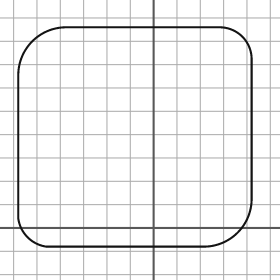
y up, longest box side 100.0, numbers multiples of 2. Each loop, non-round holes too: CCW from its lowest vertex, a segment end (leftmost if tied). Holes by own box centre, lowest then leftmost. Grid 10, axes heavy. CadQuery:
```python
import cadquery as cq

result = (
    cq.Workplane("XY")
    .moveTo(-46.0, -8.0)
    .lineTo(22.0, -8.0)
    .threePointArc((36.0, -2.0), (42.0, 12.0))
    .lineTo(42.0, 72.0)
    .threePointArc((38.0, 82.0), (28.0, 86.0))
    .lineTo(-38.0, 86.0)
    .threePointArc((-52.0, 80.0), (-58.0, 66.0))
    .lineTo(-58.0, 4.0)
    .threePointArc((-54.0, -4.0), (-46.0, -8.0))
    .close()
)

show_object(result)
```